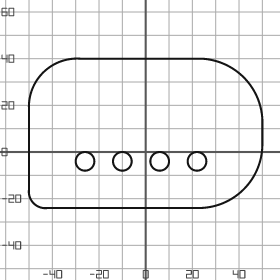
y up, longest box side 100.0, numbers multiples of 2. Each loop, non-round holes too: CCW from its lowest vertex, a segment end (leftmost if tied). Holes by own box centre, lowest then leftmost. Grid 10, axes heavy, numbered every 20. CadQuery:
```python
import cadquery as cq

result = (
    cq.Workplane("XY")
    .moveTo(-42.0, -24.0)
    .lineTo(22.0, -24.0)
    .threePointArc((42.0, -16.0), (50.0, 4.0))
    .lineTo(50.0, 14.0)
    .threePointArc((42.0, 32.0), (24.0, 40.0))
    .lineTo(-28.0, 40.0)
    .threePointArc((-44.0, 34.0), (-50.0, 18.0))
    .lineTo(-50.0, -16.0)
    .threePointArc((-48.0, -22.0), (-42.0, -24.0))
    .close()
    .moveTo(-26.0, -4.0)
    .circle(4.0)
    .moveTo(-10.0, -4.0)
    .circle(4.0)
    .moveTo(6.0, -4.0)
    .circle(4.0)
    .moveTo(22.0, -4.0)
    .circle(4.0)
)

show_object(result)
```